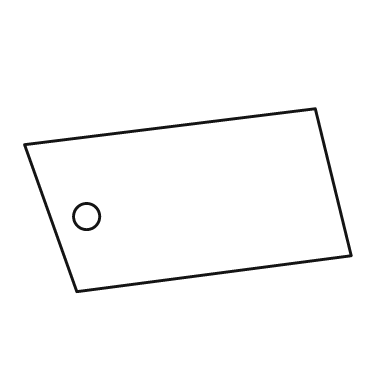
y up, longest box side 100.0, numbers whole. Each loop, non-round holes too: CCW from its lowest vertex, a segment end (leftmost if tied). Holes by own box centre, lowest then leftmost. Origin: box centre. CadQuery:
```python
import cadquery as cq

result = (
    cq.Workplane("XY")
    .moveTo(-34.0, -28.0)
    .lineTo(50.0, -17.0)
    .lineTo(39.0, 28.0)
    .lineTo(-50.0, 17.0)
    .close()
    .moveTo(-31.0, -5.0)
    .circle(4.0)
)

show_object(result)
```